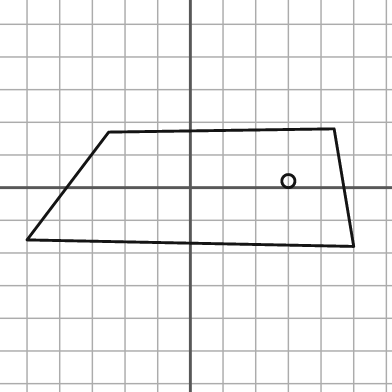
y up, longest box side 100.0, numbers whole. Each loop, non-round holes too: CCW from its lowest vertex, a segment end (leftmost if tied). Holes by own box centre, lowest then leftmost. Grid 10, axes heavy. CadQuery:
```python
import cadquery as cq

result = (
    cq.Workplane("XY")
    .moveTo(50.0, -18.0)
    .lineTo(44.0, 18.0)
    .lineTo(-25.0, 17.0)
    .lineTo(-50.0, -16.0)
    .close()
    .moveTo(30.0, 2.0)
    .circle(2.0)
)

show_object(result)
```